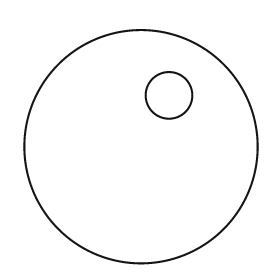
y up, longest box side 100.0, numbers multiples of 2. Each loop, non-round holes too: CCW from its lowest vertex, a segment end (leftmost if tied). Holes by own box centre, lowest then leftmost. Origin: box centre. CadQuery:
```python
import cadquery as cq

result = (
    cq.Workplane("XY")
    .moveTo(0.0, 0.0)
    .circle(50.0)
    .moveTo(12.0, 22.0)
    .circle(10.0)
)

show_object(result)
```